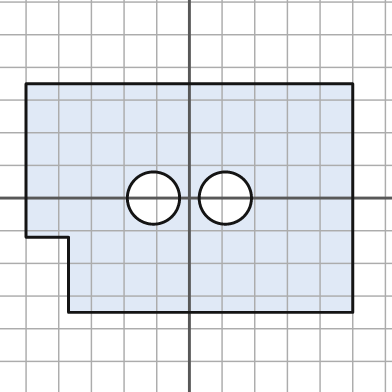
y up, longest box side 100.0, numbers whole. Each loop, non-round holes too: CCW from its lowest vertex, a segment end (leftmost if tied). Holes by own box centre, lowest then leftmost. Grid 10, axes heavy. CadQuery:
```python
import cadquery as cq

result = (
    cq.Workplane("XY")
    .moveTo(-37.0, -35.0)
    .lineTo(50.0, -35.0)
    .lineTo(50.0, 35.0)
    .lineTo(-50.0, 35.0)
    .lineTo(-50.0, -12.0)
    .lineTo(-37.0, -12.0)
    .close()
    .moveTo(-11.0, 0.0)
    .circle(8.0)
    .moveTo(11.0, 0.0)
    .circle(8.0)
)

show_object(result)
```